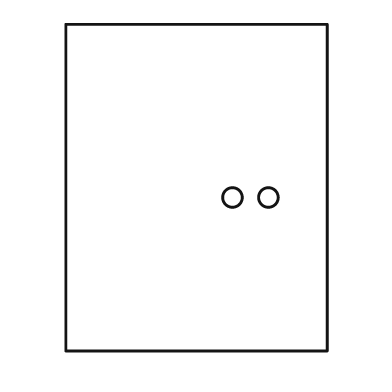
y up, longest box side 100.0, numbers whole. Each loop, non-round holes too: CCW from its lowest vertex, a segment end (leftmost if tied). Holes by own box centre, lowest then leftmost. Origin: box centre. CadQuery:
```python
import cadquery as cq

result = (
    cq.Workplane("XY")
    .moveTo(-40.0, -50.0)
    .lineTo(40.0, -50.0)
    .lineTo(40.0, 50.0)
    .lineTo(-40.0, 50.0)
    .close()
    .moveTo(11.0, -3.0)
    .circle(3.0)
    .moveTo(22.0, -3.0)
    .circle(3.0)
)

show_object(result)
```